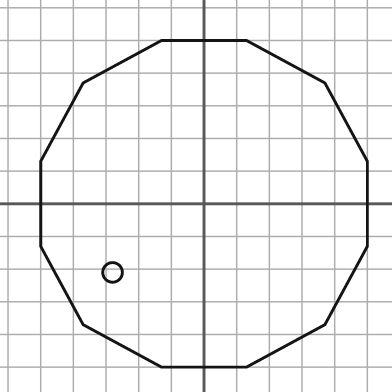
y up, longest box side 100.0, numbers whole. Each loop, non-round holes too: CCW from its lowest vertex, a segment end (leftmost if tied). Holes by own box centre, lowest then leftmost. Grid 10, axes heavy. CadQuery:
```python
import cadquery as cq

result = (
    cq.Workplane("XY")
    .moveTo(-13.0, -50.0)
    .lineTo(13.0, -50.0)
    .lineTo(37.0, -37.0)
    .lineTo(50.0, -13.0)
    .lineTo(50.0, 13.0)
    .lineTo(37.0, 37.0)
    .lineTo(13.0, 50.0)
    .lineTo(-13.0, 50.0)
    .lineTo(-37.0, 37.0)
    .lineTo(-50.0, 13.0)
    .lineTo(-50.0, -13.0)
    .lineTo(-37.0, -37.0)
    .close()
    .moveTo(-28.0, -21.0)
    .circle(3.0)
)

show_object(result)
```